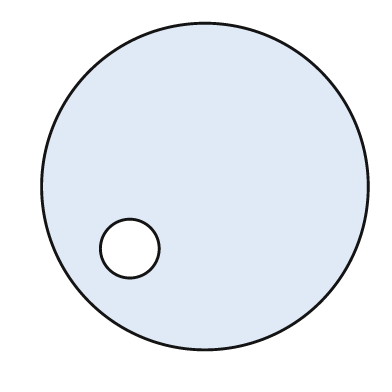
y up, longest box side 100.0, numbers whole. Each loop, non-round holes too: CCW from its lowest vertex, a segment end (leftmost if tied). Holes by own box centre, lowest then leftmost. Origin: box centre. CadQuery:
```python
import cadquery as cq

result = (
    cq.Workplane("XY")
    .moveTo(0.0, 0.0)
    .circle(50.0)
    .moveTo(-23.0, -19.0)
    .circle(9.0)
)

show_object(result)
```